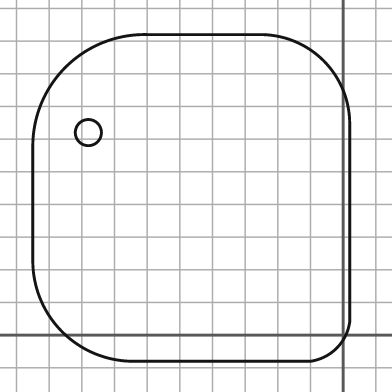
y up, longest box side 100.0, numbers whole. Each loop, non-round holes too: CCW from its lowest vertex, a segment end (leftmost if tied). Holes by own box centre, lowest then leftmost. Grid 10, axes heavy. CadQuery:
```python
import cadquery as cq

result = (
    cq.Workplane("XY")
    .moveTo(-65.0, -8.0)
    .lineTo(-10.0, -8.0)
    .threePointArc((-2.0, -4.0), (2.0, 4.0))
    .lineTo(2.0, 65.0)
    .threePointArc((-6.0, 84.0), (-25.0, 92.0))
    .lineTo(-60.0, 92.0)
    .threePointArc((-85.0, 82.0), (-95.0, 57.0))
    .lineTo(-95.0, 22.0)
    .threePointArc((-86.0, 1.0), (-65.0, -8.0))
    .close()
    .moveTo(-78.0, 62.0)
    .circle(4.0)
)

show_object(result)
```